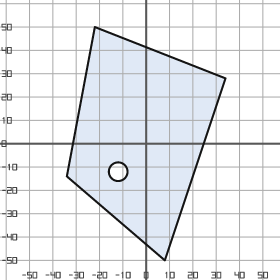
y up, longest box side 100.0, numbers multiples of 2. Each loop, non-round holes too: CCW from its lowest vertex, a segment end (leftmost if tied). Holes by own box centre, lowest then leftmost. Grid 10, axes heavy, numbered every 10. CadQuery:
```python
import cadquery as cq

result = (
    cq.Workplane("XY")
    .moveTo(8.0, -50.0)
    .lineTo(34.0, 28.0)
    .lineTo(-22.0, 50.0)
    .lineTo(-34.0, -14.0)
    .close()
    .moveTo(-12.0, -12.0)
    .circle(4.0)
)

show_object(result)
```